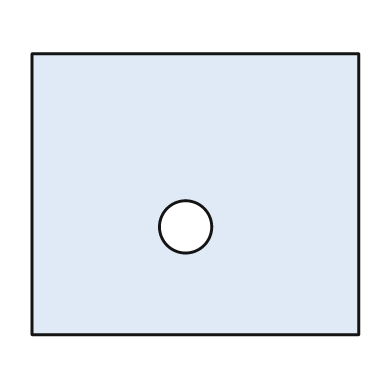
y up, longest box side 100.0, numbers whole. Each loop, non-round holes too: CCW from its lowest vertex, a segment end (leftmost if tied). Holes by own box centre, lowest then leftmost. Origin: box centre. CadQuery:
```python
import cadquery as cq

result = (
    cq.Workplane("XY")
    .moveTo(-50.0, -43.0)
    .lineTo(50.0, -43.0)
    .lineTo(50.0, 43.0)
    .lineTo(-50.0, 43.0)
    .close()
    .moveTo(-3.0, -10.0)
    .circle(8.0)
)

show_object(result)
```